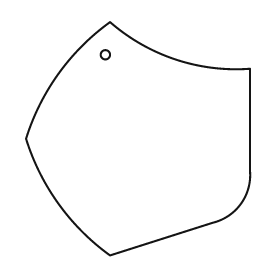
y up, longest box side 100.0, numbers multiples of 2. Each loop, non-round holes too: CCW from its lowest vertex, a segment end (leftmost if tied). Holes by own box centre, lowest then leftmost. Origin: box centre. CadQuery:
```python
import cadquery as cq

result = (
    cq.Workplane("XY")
    .moveTo(-12.0, -50.0)
    .lineTo(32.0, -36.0)
    .threePointArc((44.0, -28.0), (48.0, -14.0))
    .lineTo(48.0, 30.0)
    .threePointArc((16.0, 34.0), (-12.0, 50.0))
    .threePointArc((-34.0, 28.0), (-48.0, 0.0))
    .threePointArc((-34.0, -28.0), (-12.0, -50.0))
    .close()
    .moveTo(-14.0, 36.0)
    .circle(2.0)
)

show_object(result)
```